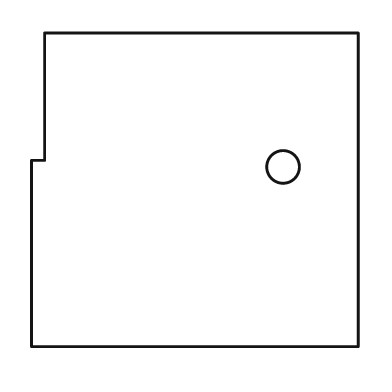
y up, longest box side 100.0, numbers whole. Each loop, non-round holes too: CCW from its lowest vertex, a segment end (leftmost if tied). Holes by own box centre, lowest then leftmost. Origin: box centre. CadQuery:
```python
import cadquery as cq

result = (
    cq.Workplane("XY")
    .moveTo(-50.0, -48.0)
    .lineTo(50.0, -48.0)
    .lineTo(50.0, 48.0)
    .lineTo(-46.0, 48.0)
    .lineTo(-46.0, 9.0)
    .lineTo(-50.0, 9.0)
    .close()
    .moveTo(27.0, 7.0)
    .circle(5.0)
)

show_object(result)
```